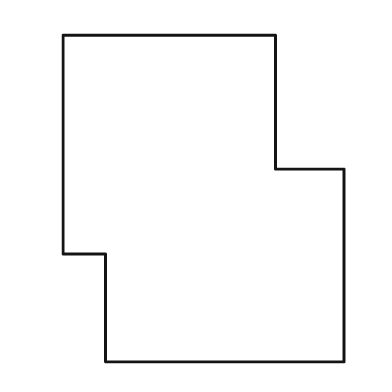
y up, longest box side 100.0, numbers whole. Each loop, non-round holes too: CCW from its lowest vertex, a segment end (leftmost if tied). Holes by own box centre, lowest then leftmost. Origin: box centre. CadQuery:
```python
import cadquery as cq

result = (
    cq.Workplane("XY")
    .moveTo(-30.0, -50.0)
    .lineTo(43.0, -50.0)
    .lineTo(43.0, 9.0)
    .lineTo(22.0, 9.0)
    .lineTo(22.0, 50.0)
    .lineTo(-43.0, 50.0)
    .lineTo(-43.0, -17.0)
    .lineTo(-30.0, -17.0)
    .close()
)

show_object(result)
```